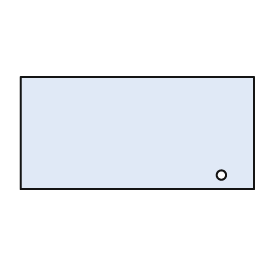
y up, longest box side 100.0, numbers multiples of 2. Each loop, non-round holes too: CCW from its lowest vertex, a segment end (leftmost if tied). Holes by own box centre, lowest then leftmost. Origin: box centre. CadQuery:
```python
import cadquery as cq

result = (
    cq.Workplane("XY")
    .moveTo(-50.0, -24.0)
    .lineTo(50.0, -24.0)
    .lineTo(50.0, 24.0)
    .lineTo(-50.0, 24.0)
    .close()
    .moveTo(36.0, -18.0)
    .circle(2.0)
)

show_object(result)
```